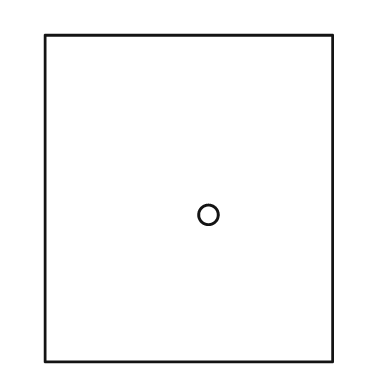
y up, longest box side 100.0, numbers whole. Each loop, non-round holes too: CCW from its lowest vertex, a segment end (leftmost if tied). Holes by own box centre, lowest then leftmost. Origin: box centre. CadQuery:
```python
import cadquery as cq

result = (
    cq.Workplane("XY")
    .moveTo(-44.0, -50.0)
    .lineTo(44.0, -50.0)
    .lineTo(44.0, 50.0)
    .lineTo(-44.0, 50.0)
    .close()
    .moveTo(6.0, -5.0)
    .circle(3.0)
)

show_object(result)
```